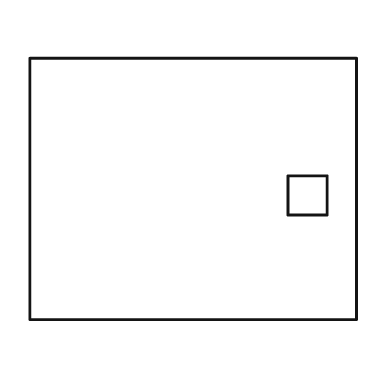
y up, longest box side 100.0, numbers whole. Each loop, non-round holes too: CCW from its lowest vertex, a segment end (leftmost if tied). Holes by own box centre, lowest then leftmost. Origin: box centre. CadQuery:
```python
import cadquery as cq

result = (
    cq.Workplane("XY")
    .moveTo(-50.0, -40.0)
    .lineTo(50.0, -40.0)
    .lineTo(50.0, 40.0)
    .lineTo(-50.0, 40.0)
    .close()
    .moveTo(29.0, -8.0)
    .lineTo(41.0, -8.0)
    .lineTo(41.0, 4.0)
    .lineTo(29.0, 4.0)
    .close()
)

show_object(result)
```